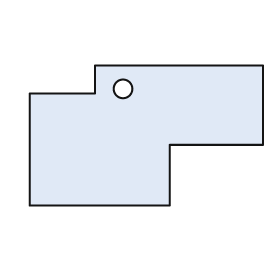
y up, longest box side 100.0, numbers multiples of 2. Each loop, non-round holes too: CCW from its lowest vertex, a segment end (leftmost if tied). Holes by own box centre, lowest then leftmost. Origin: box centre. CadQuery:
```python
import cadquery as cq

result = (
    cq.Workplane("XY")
    .moveTo(-50.0, -30.0)
    .lineTo(10.0, -30.0)
    .lineTo(10.0, -4.0)
    .lineTo(50.0, -4.0)
    .lineTo(50.0, 30.0)
    .lineTo(-22.0, 30.0)
    .lineTo(-22.0, 18.0)
    .lineTo(-50.0, 18.0)
    .close()
    .moveTo(-10.0, 20.0)
    .circle(4.0)
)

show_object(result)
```